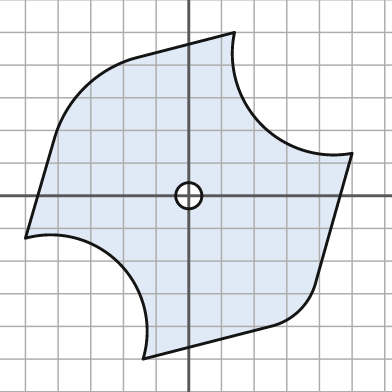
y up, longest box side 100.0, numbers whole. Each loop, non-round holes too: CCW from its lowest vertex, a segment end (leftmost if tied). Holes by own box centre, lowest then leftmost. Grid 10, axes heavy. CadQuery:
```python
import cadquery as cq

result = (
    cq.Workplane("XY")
    .moveTo(-14.0, -50.0)
    .lineTo(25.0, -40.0)
    .threePointArc((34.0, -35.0), (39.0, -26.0))
    .lineTo(50.0, 13.0)
    .threePointArc((22.0, 22.0), (14.0, 50.0))
    .lineTo(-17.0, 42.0)
    .threePointArc((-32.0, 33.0), (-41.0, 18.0))
    .lineTo(-50.0, -13.0)
    .threePointArc((-21.0, -21.0), (-14.0, -50.0))
    .close()
    .moveTo(0.0, 0.0)
    .circle(4.0)
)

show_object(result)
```